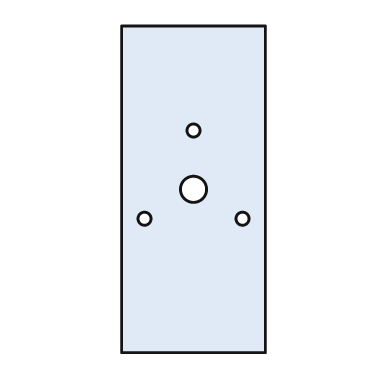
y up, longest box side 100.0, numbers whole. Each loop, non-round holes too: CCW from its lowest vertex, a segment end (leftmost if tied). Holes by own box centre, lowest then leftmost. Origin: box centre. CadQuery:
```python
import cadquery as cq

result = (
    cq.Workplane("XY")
    .moveTo(-22.0, -50.0)
    .lineTo(22.0, -50.0)
    .lineTo(22.0, 50.0)
    .lineTo(-22.0, 50.0)
    .close()
    .moveTo(-15.0, -9.0)
    .circle(2.0)
    .moveTo(15.0, -9.0)
    .circle(2.0)
    .moveTo(0.0, 0.0)
    .circle(4.0)
    .moveTo(0.0, 18.0)
    .circle(2.0)
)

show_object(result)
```